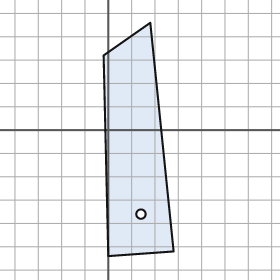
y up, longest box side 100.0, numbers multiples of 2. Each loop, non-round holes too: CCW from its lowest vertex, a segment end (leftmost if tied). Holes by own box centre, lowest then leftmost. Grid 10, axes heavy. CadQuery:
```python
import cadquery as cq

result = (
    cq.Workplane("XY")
    .moveTo(0.0, -54.0)
    .lineTo(28.0, -52.0)
    .lineTo(18.0, 46.0)
    .lineTo(-2.0, 32.0)
    .close()
    .moveTo(14.0, -36.0)
    .circle(2.0)
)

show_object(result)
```